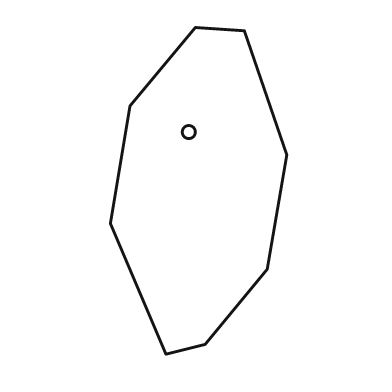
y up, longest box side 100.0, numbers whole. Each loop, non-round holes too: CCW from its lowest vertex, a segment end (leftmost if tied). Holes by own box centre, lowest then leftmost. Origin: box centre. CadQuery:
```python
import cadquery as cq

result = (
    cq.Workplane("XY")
    .moveTo(-10.0, -50.0)
    .lineTo(2.0, -47.0)
    .lineTo(21.0, -24.0)
    .lineTo(27.0, 11.0)
    .lineTo(14.0, 49.0)
    .lineTo(-1.0, 50.0)
    .lineTo(-21.0, 26.0)
    .lineTo(-27.0, -10.0)
    .close()
    .moveTo(-3.0, 18.0)
    .circle(2.0)
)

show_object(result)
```